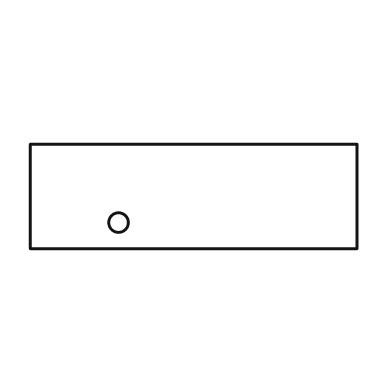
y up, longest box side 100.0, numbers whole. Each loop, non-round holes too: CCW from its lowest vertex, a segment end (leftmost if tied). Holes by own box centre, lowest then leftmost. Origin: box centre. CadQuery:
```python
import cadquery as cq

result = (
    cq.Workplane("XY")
    .moveTo(-50.0, -16.0)
    .lineTo(50.0, -16.0)
    .lineTo(50.0, 16.0)
    .lineTo(-50.0, 16.0)
    .close()
    .moveTo(-23.0, -8.0)
    .circle(3.0)
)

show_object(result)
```